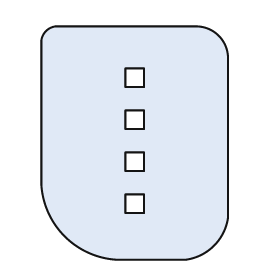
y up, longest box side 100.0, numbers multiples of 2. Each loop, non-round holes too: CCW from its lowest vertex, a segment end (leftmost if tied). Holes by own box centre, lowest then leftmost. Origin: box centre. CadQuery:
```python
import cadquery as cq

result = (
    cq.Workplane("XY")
    .moveTo(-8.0, -50.0)
    .lineTo(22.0, -50.0)
    .threePointArc((34.0, -44.0), (40.0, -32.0))
    .lineTo(40.0, 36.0)
    .threePointArc((36.0, 46.0), (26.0, 50.0))
    .lineTo(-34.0, 50.0)
    .threePointArc((-38.0, 48.0), (-40.0, 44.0))
    .lineTo(-40.0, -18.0)
    .threePointArc((-30.0, -40.0), (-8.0, -50.0))
    .close()
    .moveTo(-4.0, -30.0)
    .lineTo(4.0, -30.0)
    .lineTo(4.0, -22.0)
    .lineTo(-4.0, -22.0)
    .close()
    .moveTo(-4.0, -12.0)
    .lineTo(4.0, -12.0)
    .lineTo(4.0, -4.0)
    .lineTo(-4.0, -4.0)
    .close()
    .moveTo(-4.0, 6.0)
    .lineTo(4.0, 6.0)
    .lineTo(4.0, 14.0)
    .lineTo(-4.0, 14.0)
    .close()
    .moveTo(-4.0, 24.0)
    .lineTo(4.0, 24.0)
    .lineTo(4.0, 32.0)
    .lineTo(-4.0, 32.0)
    .close()
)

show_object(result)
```